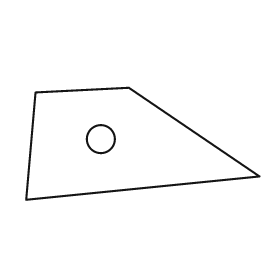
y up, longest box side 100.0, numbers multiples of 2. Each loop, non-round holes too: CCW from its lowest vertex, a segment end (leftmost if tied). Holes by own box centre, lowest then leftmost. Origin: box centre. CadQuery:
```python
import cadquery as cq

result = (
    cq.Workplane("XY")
    .moveTo(-50.0, -24.0)
    .lineTo(50.0, -14.0)
    .lineTo(-6.0, 24.0)
    .lineTo(-46.0, 22.0)
    .close()
    .moveTo(-18.0, 2.0)
    .circle(6.0)
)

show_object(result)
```